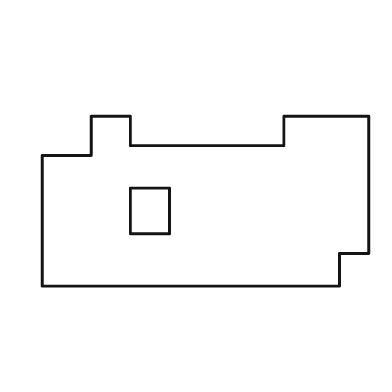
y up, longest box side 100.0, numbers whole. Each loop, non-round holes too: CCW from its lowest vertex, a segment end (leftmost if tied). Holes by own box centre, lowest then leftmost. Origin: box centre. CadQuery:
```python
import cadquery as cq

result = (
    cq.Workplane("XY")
    .moveTo(-50.0, -26.0)
    .lineTo(41.0, -26.0)
    .lineTo(41.0, -16.0)
    .lineTo(50.0, -16.0)
    .lineTo(50.0, 26.0)
    .lineTo(24.0, 26.0)
    .lineTo(24.0, 17.0)
    .lineTo(-23.0, 17.0)
    .lineTo(-23.0, 26.0)
    .lineTo(-35.0, 26.0)
    .lineTo(-35.0, 14.0)
    .lineTo(-50.0, 14.0)
    .close()
    .moveTo(-23.0, -10.0)
    .lineTo(-11.0, -10.0)
    .lineTo(-11.0, 4.0)
    .lineTo(-23.0, 4.0)
    .close()
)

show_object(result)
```